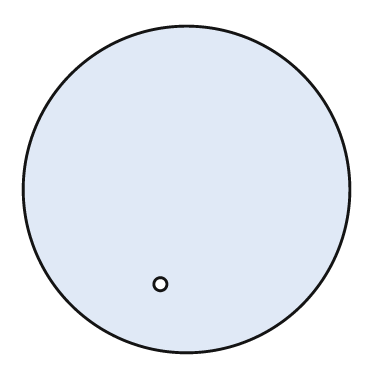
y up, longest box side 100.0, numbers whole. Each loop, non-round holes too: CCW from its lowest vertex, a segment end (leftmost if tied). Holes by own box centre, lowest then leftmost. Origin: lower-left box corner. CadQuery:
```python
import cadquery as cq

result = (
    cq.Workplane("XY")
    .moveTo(50.0, 50.0)
    .circle(50.0)
    .moveTo(42.0, 21.0)
    .circle(2.0)
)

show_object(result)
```